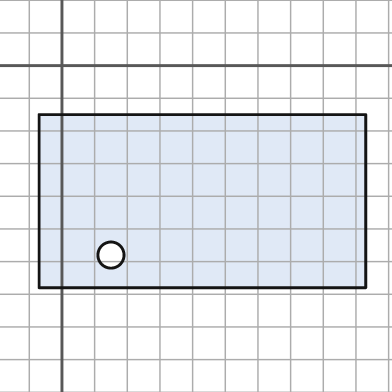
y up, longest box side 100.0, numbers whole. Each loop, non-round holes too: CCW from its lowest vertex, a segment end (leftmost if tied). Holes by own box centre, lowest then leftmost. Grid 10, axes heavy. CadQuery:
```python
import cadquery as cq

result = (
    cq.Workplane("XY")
    .moveTo(-7.0, -68.0)
    .lineTo(93.0, -68.0)
    .lineTo(93.0, -15.0)
    .lineTo(-7.0, -15.0)
    .close()
    .moveTo(15.0, -58.0)
    .circle(4.0)
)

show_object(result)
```